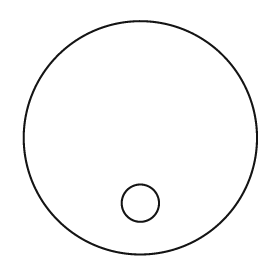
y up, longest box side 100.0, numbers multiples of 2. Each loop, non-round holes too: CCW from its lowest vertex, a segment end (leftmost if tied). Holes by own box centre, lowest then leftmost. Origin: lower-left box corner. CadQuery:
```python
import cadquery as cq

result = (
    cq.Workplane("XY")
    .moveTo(50.0, 50.0)
    .circle(50.0)
    .moveTo(50.0, 22.0)
    .circle(8.0)
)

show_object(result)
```